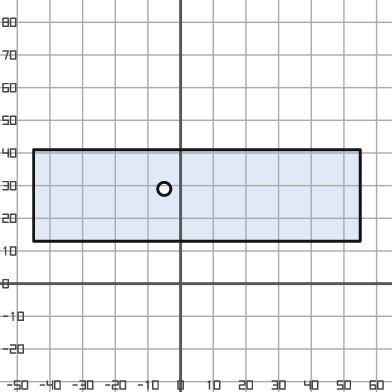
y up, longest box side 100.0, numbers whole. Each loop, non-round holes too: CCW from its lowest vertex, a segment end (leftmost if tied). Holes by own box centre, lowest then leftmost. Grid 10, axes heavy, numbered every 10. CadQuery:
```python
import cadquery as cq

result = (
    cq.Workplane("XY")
    .moveTo(-45.0, 13.0)
    .lineTo(55.0, 13.0)
    .lineTo(55.0, 41.0)
    .lineTo(-45.0, 41.0)
    .close()
    .moveTo(-5.0, 29.0)
    .circle(2.0)
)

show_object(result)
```